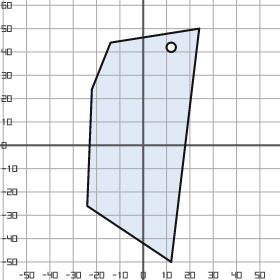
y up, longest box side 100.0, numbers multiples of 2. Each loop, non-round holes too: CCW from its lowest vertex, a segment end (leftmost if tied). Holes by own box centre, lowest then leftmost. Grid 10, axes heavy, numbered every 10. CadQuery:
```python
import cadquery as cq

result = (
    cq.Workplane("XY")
    .moveTo(12.0, -50.0)
    .lineTo(24.0, 50.0)
    .lineTo(-14.0, 44.0)
    .lineTo(-22.0, 24.0)
    .lineTo(-24.0, -26.0)
    .close()
    .moveTo(12.0, 42.0)
    .circle(2.0)
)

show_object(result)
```